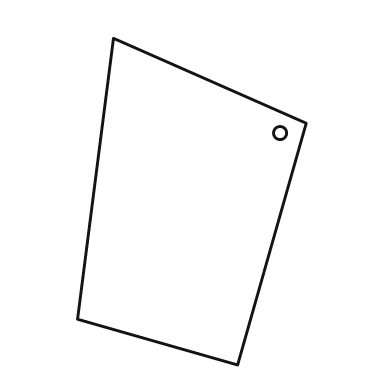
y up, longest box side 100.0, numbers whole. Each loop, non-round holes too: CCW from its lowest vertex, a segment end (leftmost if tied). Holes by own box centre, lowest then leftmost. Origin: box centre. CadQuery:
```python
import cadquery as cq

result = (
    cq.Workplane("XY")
    .moveTo(14.0, -50.0)
    .lineTo(35.0, 24.0)
    .lineTo(-24.0, 50.0)
    .lineTo(-35.0, -36.0)
    .close()
    .moveTo(27.0, 21.0)
    .circle(2.0)
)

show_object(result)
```